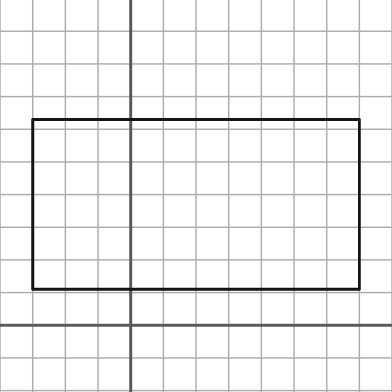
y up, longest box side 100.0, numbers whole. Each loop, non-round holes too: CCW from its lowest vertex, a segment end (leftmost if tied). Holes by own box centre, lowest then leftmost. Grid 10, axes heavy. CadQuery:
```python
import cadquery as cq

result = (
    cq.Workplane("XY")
    .moveTo(-30.0, 11.0)
    .lineTo(70.0, 11.0)
    .lineTo(70.0, 63.0)
    .lineTo(-30.0, 63.0)
    .close()
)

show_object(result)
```